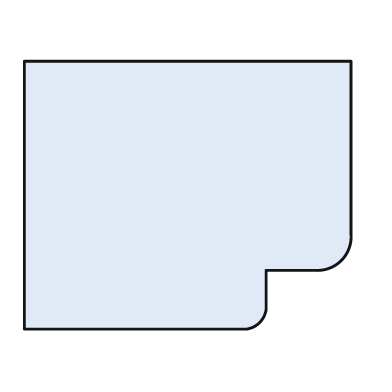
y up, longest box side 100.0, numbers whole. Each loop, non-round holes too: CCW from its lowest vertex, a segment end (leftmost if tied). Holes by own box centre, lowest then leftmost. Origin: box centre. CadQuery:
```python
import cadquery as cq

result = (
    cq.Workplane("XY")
    .moveTo(-50.0, -41.0)
    .lineTo(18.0, -41.0)
    .threePointArc((22.0, -39.0), (24.0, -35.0))
    .lineTo(24.0, -23.0)
    .lineTo(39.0, -23.0)
    .threePointArc((47.0, -20.0), (50.0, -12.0))
    .lineTo(50.0, 41.0)
    .lineTo(-50.0, 41.0)
    .close()
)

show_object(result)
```